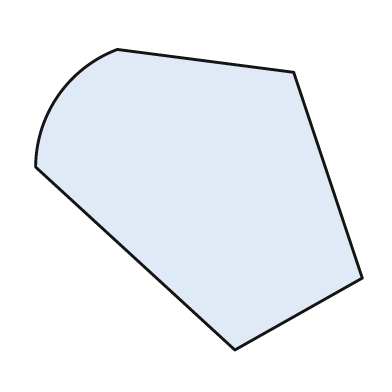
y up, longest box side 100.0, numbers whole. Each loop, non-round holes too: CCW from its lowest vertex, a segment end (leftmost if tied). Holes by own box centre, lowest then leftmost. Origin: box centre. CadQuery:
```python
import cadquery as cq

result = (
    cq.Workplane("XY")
    .moveTo(11.0, -46.0)
    .lineTo(50.0, -24.0)
    .lineTo(29.0, 39.0)
    .lineTo(-25.0, 46.0)
    .threePointArc((-43.0, 32.0), (-50.0, 10.0))
    .close()
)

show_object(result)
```